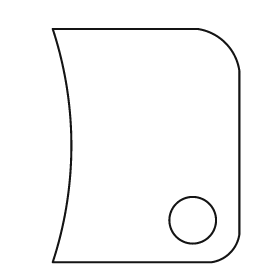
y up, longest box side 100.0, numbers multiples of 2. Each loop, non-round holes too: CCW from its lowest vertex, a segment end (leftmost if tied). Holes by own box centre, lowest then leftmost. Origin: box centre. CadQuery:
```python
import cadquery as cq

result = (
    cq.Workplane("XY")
    .moveTo(-40.0, -50.0)
    .lineTo(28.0, -50.0)
    .threePointArc((36.0, -46.0), (40.0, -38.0))
    .lineTo(40.0, 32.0)
    .threePointArc((34.0, 44.0), (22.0, 50.0))
    .lineTo(-40.0, 50.0)
    .threePointArc((-32.0, 0.0), (-40.0, -50.0))
    .close()
    .moveTo(20.0, -32.0)
    .circle(10.0)
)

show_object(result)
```